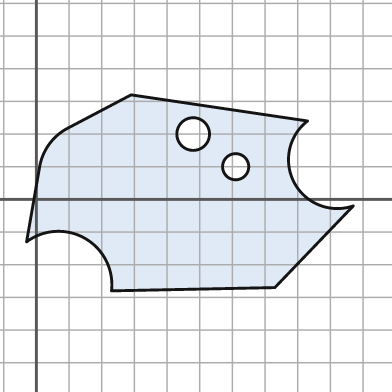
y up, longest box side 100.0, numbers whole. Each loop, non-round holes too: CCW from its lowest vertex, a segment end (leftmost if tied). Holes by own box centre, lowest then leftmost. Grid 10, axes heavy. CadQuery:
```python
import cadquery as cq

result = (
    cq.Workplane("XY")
    .moveTo(23.0, -28.0)
    .lineTo(73.0, -27.0)
    .lineTo(97.0, -2.0)
    .threePointArc((79.0, 5.0), (83.0, 24.0))
    .lineTo(29.0, 32.0)
    .lineTo(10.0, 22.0)
    .threePointArc((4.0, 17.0), (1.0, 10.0))
    .lineTo(-3.0, -13.0)
    .threePointArc((15.0, -12.0), (23.0, -28.0))
    .close()
    .moveTo(61.0, 10.0)
    .circle(4.0)
    .moveTo(48.0, 20.0)
    .circle(5.0)
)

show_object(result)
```